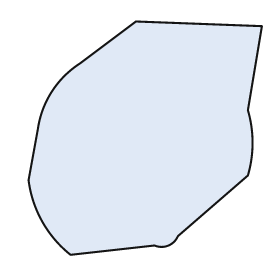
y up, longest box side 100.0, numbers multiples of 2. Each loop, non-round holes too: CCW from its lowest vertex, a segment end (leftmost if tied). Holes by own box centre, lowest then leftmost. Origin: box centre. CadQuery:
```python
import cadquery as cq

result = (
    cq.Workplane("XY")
    .moveTo(-32.0, -50.0)
    .lineTo(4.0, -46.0)
    .threePointArc((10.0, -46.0), (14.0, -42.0))
    .lineTo(44.0, -16.0)
    .threePointArc((46.0, -2.0), (44.0, 12.0))
    .lineTo(50.0, 48.0)
    .lineTo(-4.0, 50.0)
    .lineTo(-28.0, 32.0)
    .threePointArc((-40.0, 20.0), (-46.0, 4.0))
    .lineTo(-50.0, -18.0)
    .threePointArc((-44.0, -36.0), (-32.0, -50.0))
    .close()
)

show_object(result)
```